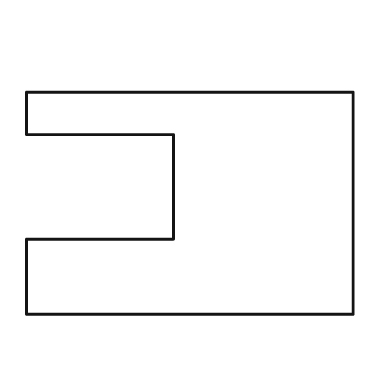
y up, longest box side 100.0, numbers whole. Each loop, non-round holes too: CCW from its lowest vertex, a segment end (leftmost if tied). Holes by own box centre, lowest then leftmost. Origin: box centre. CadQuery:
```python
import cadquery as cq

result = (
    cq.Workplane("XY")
    .moveTo(-50.0, -34.0)
    .lineTo(50.0, -34.0)
    .lineTo(50.0, 34.0)
    .lineTo(-50.0, 34.0)
    .lineTo(-50.0, 21.0)
    .lineTo(-5.0, 21.0)
    .lineTo(-5.0, -11.0)
    .lineTo(-50.0, -11.0)
    .close()
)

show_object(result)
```